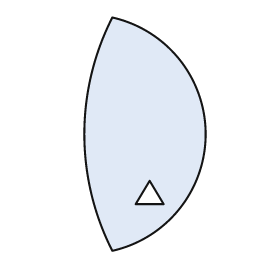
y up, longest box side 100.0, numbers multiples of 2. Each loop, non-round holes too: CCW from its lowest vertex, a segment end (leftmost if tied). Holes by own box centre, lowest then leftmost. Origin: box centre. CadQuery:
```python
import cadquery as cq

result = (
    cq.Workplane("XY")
    .moveTo(-14.0, -50.0)
    .threePointArc((26.0, 0.0), (-14.0, 50.0))
    .threePointArc((-26.0, 0.0), (-14.0, -50.0))
    .close()
    .moveTo(-4.0, -30.0)
    .lineTo(8.0, -30.0)
    .lineTo(2.0, -20.0)
    .close()
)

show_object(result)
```